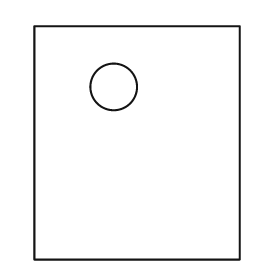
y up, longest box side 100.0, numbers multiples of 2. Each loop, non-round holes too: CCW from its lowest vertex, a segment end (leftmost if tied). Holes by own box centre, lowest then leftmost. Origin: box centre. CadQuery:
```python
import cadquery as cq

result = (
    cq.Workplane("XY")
    .moveTo(-44.0, -50.0)
    .lineTo(44.0, -50.0)
    .lineTo(44.0, 50.0)
    .lineTo(-44.0, 50.0)
    .close()
    .moveTo(-10.0, 24.0)
    .circle(10.0)
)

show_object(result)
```